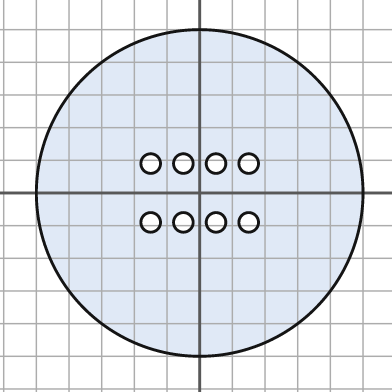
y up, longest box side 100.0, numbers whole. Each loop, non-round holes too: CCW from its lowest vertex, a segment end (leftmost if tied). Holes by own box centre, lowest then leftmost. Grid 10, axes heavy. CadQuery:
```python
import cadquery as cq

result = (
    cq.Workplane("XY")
    .moveTo(0.0, 0.0)
    .circle(50.0)
    .moveTo(-15.0, -9.0)
    .circle(3.0)
    .moveTo(-5.0, -9.0)
    .circle(3.0)
    .moveTo(5.0, -9.0)
    .circle(3.0)
    .moveTo(15.0, -9.0)
    .circle(3.0)
    .moveTo(-15.0, 9.0)
    .circle(3.0)
    .moveTo(-5.0, 9.0)
    .circle(3.0)
    .moveTo(5.0, 9.0)
    .circle(3.0)
    .moveTo(15.0, 9.0)
    .circle(3.0)
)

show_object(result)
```